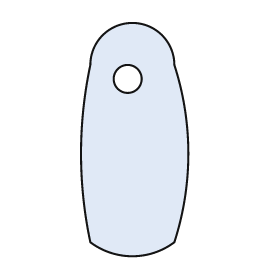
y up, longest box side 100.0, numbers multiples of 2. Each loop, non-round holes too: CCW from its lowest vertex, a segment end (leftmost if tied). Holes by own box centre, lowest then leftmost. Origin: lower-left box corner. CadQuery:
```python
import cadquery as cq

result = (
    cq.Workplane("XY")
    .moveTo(4.0, 6.0)
    .threePointArc((22.0, 0.0), (40.0, 6.0))
    .threePointArc((46.0, 44.0), (40.0, 82.0))
    .threePointArc((22.0, 100.0), (4.0, 82.0))
    .threePointArc((0.0, 44.0), (4.0, 6.0))
    .close()
    .moveTo(20.0, 76.0)
    .circle(6.0)
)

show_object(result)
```